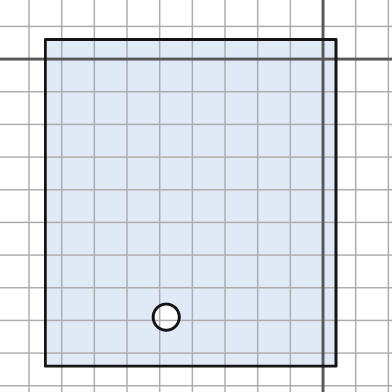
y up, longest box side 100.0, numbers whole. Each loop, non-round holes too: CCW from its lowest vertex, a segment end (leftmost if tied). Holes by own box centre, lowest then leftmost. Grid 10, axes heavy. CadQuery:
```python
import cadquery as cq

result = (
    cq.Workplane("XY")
    .moveTo(-85.0, -94.0)
    .lineTo(4.0, -94.0)
    .lineTo(4.0, 6.0)
    .lineTo(-85.0, 6.0)
    .close()
    .moveTo(-48.0, -79.0)
    .circle(4.0)
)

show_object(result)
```